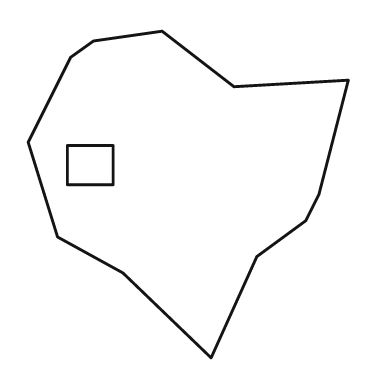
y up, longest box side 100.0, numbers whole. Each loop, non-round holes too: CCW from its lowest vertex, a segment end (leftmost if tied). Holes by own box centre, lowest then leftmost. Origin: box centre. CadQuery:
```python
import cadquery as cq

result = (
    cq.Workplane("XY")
    .moveTo(7.0, -50.0)
    .lineTo(21.0, -19.0)
    .lineTo(36.0, -8.0)
    .lineTo(40.0, 0.0)
    .lineTo(49.0, 35.0)
    .lineTo(14.0, 33.0)
    .lineTo(-8.0, 50.0)
    .lineTo(-29.0, 47.0)
    .lineTo(-36.0, 42.0)
    .lineTo(-49.0, 16.0)
    .lineTo(-40.0, -13.0)
    .lineTo(-20.0, -24.0)
    .close()
    .moveTo(-37.0, 3.0)
    .lineTo(-23.0, 3.0)
    .lineTo(-23.0, 15.0)
    .lineTo(-37.0, 15.0)
    .close()
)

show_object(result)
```